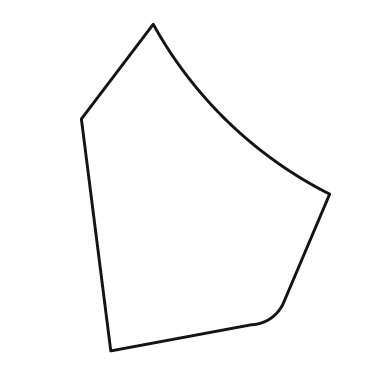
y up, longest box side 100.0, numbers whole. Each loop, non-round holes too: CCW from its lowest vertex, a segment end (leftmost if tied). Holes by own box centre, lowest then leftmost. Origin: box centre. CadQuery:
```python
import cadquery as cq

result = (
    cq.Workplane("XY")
    .moveTo(-29.0, -50.0)
    .lineTo(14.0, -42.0)
    .threePointArc((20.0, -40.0), (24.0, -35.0))
    .lineTo(38.0, -2.0)
    .threePointArc((7.0, 20.0), (-16.0, 50.0))
    .lineTo(-38.0, 21.0)
    .close()
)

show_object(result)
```